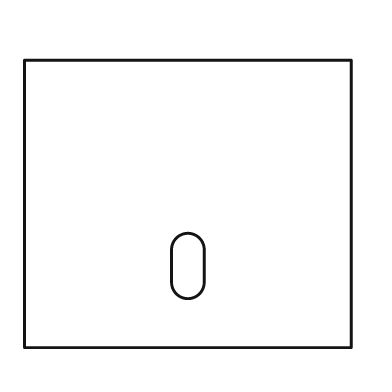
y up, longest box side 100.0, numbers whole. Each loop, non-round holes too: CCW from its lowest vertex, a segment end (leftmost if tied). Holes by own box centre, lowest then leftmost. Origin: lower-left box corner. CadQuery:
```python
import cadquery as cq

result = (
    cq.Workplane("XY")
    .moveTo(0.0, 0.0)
    .lineTo(100.0, 0.0)
    .lineTo(100.0, 88.0)
    .lineTo(0.0, 88.0)
    .close()
    .moveTo(45.0, 20.0)
    .threePointArc((50.0, 15.0), (55.0, 20.0))
    .lineTo(55.0, 30.0)
    .threePointArc((50.0, 35.0), (45.0, 30.0))
    .close()
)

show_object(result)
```